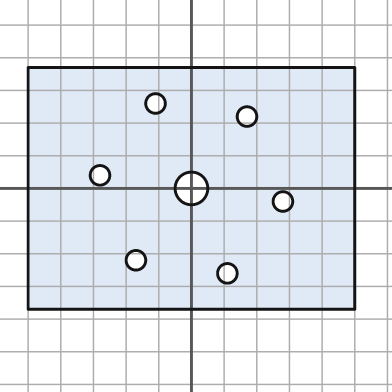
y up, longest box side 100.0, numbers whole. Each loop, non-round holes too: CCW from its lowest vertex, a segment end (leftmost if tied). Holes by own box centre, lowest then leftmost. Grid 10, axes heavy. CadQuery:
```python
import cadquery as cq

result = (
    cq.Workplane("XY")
    .moveTo(-50.0, -37.0)
    .lineTo(50.0, -37.0)
    .lineTo(50.0, 37.0)
    .lineTo(-50.0, 37.0)
    .close()
    .moveTo(11.0, -26.0)
    .circle(3.0)
    .moveTo(-17.0, -22.0)
    .circle(3.0)
    .moveTo(28.0, -4.0)
    .circle(3.0)
    .moveTo(0.0, 0.0)
    .circle(5.0)
    .moveTo(-28.0, 4.0)
    .circle(3.0)
    .moveTo(17.0, 22.0)
    .circle(3.0)
    .moveTo(-11.0, 26.0)
    .circle(3.0)
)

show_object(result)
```